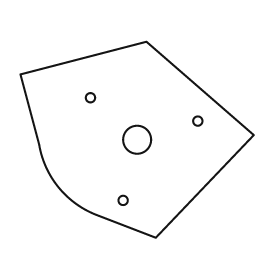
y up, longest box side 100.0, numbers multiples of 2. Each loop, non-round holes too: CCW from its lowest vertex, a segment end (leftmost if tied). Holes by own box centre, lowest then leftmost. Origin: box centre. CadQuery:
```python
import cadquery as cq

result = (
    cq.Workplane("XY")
    .moveTo(8.0, -42.0)
    .lineTo(50.0, 2.0)
    .lineTo(4.0, 42.0)
    .lineTo(-50.0, 28.0)
    .lineTo(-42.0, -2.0)
    .threePointArc((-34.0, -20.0), (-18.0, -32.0))
    .close()
    .moveTo(-6.0, -26.0)
    .circle(2.0)
    .moveTo(0.0, 0.0)
    .circle(6.0)
    .moveTo(26.0, 8.0)
    .circle(2.0)
    .moveTo(-20.0, 18.0)
    .circle(2.0)
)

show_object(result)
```